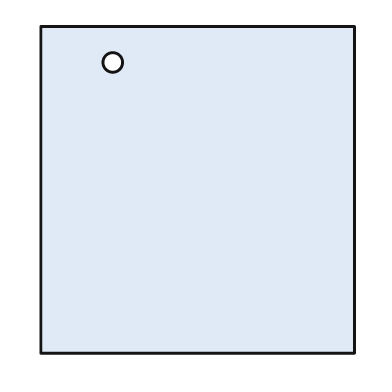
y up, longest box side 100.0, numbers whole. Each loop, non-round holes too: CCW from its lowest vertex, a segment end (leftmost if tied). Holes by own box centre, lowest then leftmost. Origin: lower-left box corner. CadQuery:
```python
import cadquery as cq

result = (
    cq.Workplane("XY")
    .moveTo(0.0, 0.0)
    .lineTo(96.0, 0.0)
    .lineTo(96.0, 100.0)
    .lineTo(0.0, 100.0)
    .close()
    .moveTo(22.0, 89.0)
    .circle(3.0)
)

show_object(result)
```